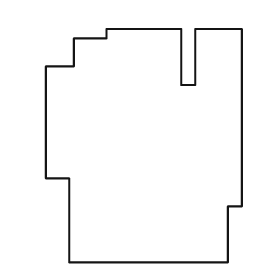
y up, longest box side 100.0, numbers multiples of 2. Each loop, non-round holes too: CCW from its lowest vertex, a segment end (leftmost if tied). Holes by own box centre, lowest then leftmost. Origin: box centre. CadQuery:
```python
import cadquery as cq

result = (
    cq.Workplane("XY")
    .moveTo(-32.0, -50.0)
    .lineTo(36.0, -50.0)
    .lineTo(36.0, -26.0)
    .lineTo(42.0, -26.0)
    .lineTo(42.0, 50.0)
    .lineTo(22.0, 50.0)
    .lineTo(22.0, 26.0)
    .lineTo(16.0, 26.0)
    .lineTo(16.0, 50.0)
    .lineTo(-16.0, 50.0)
    .lineTo(-16.0, 46.0)
    .lineTo(-30.0, 46.0)
    .lineTo(-30.0, 34.0)
    .lineTo(-42.0, 34.0)
    .lineTo(-42.0, -14.0)
    .lineTo(-32.0, -14.0)
    .close()
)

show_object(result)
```